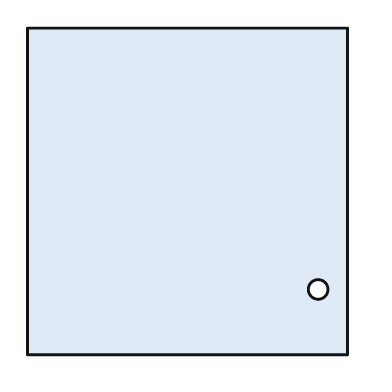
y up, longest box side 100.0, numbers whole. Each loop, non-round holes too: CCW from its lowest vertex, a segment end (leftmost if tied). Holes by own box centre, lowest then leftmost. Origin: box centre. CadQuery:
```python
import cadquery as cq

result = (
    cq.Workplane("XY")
    .moveTo(-49.0, -50.0)
    .lineTo(49.0, -50.0)
    .lineTo(49.0, 50.0)
    .lineTo(-49.0, 50.0)
    .close()
    .moveTo(40.0, -30.0)
    .circle(3.0)
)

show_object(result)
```